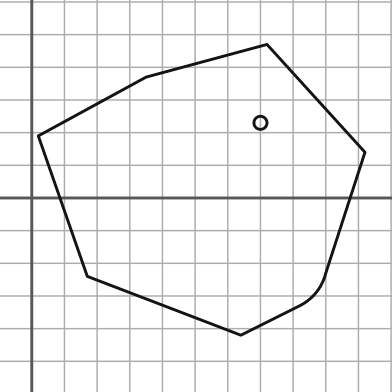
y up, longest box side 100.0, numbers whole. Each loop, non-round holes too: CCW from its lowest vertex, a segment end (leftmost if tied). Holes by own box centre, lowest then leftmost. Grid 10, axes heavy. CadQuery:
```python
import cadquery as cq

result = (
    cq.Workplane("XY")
    .moveTo(64.0, -42.0)
    .lineTo(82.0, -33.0)
    .threePointArc((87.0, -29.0), (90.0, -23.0))
    .lineTo(102.0, 14.0)
    .lineTo(72.0, 47.0)
    .lineTo(35.0, 37.0)
    .lineTo(2.0, 19.0)
    .lineTo(17.0, -24.0)
    .close()
    .moveTo(70.0, 23.0)
    .circle(2.0)
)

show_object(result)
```